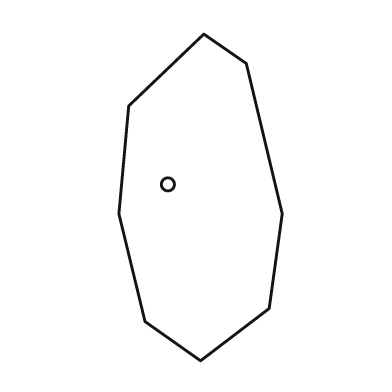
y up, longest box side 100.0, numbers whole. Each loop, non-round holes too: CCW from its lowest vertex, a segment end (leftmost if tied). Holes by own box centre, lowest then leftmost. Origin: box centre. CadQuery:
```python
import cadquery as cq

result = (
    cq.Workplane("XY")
    .moveTo(0.0, -50.0)
    .lineTo(21.0, -34.0)
    .lineTo(25.0, -5.0)
    .lineTo(14.0, 41.0)
    .lineTo(1.0, 50.0)
    .lineTo(-22.0, 28.0)
    .lineTo(-25.0, -5.0)
    .lineTo(-17.0, -38.0)
    .close()
    .moveTo(-10.0, 4.0)
    .circle(2.0)
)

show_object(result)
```